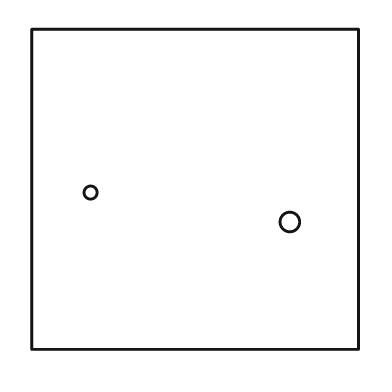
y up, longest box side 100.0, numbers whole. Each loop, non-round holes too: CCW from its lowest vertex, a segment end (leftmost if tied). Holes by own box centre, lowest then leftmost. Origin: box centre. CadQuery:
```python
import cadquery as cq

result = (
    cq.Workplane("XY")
    .moveTo(-50.0, -49.0)
    .lineTo(50.0, -49.0)
    .lineTo(50.0, 49.0)
    .lineTo(-50.0, 49.0)
    .close()
    .moveTo(29.0, -10.0)
    .circle(3.0)
    .moveTo(-32.0, -1.0)
    .circle(2.0)
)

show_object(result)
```